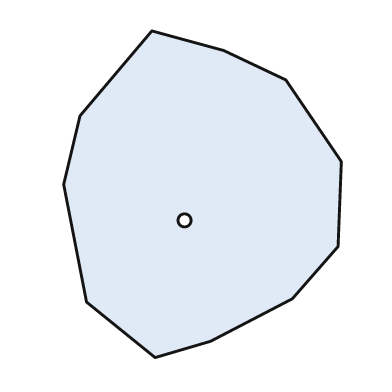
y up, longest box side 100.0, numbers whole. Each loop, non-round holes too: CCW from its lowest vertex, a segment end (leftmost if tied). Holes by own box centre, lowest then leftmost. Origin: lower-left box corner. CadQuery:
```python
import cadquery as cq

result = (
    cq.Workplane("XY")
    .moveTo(28.0, 0.0)
    .lineTo(45.0, 5.0)
    .lineTo(70.0, 18.0)
    .lineTo(84.0, 34.0)
    .lineTo(85.0, 60.0)
    .lineTo(68.0, 85.0)
    .lineTo(49.0, 94.0)
    .lineTo(27.0, 100.0)
    .lineTo(5.0, 74.0)
    .lineTo(0.0, 53.0)
    .lineTo(7.0, 17.0)
    .close()
    .moveTo(37.0, 42.0)
    .circle(2.0)
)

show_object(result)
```